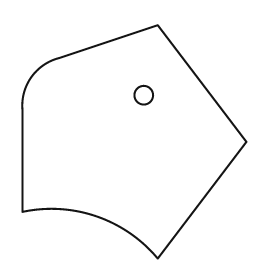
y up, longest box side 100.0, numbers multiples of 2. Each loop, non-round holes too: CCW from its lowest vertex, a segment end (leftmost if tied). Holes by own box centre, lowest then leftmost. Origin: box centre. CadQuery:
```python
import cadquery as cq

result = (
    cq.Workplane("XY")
    .moveTo(10.0, -50.0)
    .lineTo(48.0, 0.0)
    .lineTo(10.0, 50.0)
    .lineTo(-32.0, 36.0)
    .threePointArc((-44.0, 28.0), (-48.0, 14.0))
    .lineTo(-48.0, -30.0)
    .threePointArc((-16.0, -32.0), (10.0, -50.0))
    .close()
    .moveTo(4.0, 20.0)
    .circle(4.0)
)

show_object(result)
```